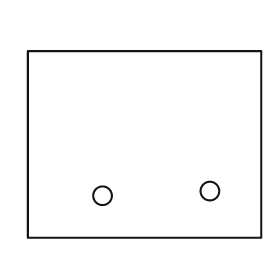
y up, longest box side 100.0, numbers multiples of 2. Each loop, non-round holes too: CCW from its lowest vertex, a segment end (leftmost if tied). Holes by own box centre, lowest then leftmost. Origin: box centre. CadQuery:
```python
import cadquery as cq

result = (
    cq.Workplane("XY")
    .moveTo(-50.0, -40.0)
    .lineTo(50.0, -40.0)
    .lineTo(50.0, 40.0)
    .lineTo(-50.0, 40.0)
    .close()
    .moveTo(-18.0, -22.0)
    .circle(4.0)
    .moveTo(28.0, -20.0)
    .circle(4.0)
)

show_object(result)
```